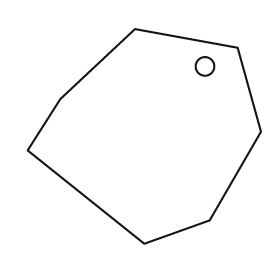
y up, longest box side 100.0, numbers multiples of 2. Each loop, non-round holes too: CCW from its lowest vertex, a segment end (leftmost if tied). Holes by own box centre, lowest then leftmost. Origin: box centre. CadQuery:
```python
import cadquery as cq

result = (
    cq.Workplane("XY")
    .moveTo(0.0, -46.0)
    .lineTo(28.0, -36.0)
    .lineTo(50.0, 2.0)
    .lineTo(40.0, 38.0)
    .lineTo(-4.0, 46.0)
    .lineTo(-36.0, 16.0)
    .lineTo(-50.0, -6.0)
    .close()
    .moveTo(26.0, 30.0)
    .circle(4.0)
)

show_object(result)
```